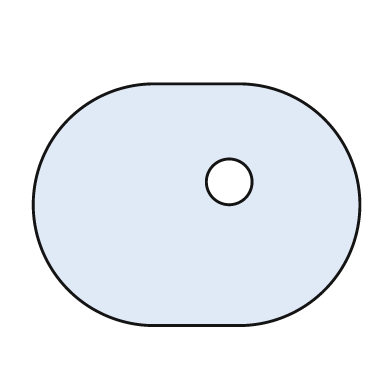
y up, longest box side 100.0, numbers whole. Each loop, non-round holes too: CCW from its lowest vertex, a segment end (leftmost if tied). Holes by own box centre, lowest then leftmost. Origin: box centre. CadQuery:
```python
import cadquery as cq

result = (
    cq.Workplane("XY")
    .moveTo(-13.0, -37.0)
    .lineTo(13.0, -37.0)
    .threePointArc((50.0, 0.0), (13.0, 37.0))
    .lineTo(-13.0, 37.0)
    .threePointArc((-50.0, 0.0), (-13.0, -37.0))
    .close()
    .moveTo(10.0, 7.0)
    .circle(7.0)
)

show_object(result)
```